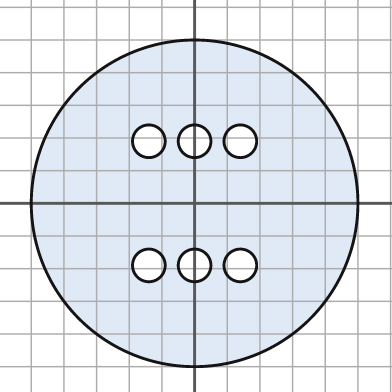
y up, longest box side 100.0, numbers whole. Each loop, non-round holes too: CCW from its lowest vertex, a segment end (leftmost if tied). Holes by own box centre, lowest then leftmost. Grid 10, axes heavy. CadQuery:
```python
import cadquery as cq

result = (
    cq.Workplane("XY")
    .moveTo(0.0, 0.0)
    .circle(50.0)
    .moveTo(-14.0, -19.0)
    .circle(5.0)
    .moveTo(0.0, -19.0)
    .circle(5.0)
    .moveTo(14.0, -19.0)
    .circle(5.0)
    .moveTo(-14.0, 19.0)
    .circle(5.0)
    .moveTo(0.0, 19.0)
    .circle(5.0)
    .moveTo(14.0, 19.0)
    .circle(5.0)
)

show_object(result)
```